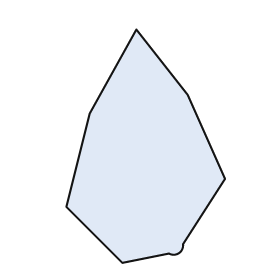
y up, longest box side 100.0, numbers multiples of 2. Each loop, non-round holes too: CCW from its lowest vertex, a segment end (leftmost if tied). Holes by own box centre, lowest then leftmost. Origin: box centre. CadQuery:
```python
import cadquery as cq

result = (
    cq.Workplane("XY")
    .moveTo(-10.0, -50.0)
    .lineTo(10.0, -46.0)
    .threePointArc((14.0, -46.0), (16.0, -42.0))
    .lineTo(34.0, -14.0)
    .lineTo(18.0, 22.0)
    .lineTo(-4.0, 50.0)
    .lineTo(-24.0, 14.0)
    .lineTo(-34.0, -26.0)
    .close()
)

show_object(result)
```